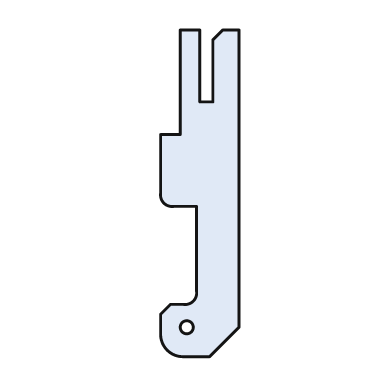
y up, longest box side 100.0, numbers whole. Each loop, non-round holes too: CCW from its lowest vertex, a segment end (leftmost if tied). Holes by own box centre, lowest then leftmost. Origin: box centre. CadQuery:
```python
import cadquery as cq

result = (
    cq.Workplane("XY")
    .moveTo(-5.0, -50.0)
    .lineTo(3.0, -50.0)
    .lineTo(12.0, -41.0)
    .lineTo(12.0, 50.0)
    .lineTo(7.0, 50.0)
    .lineTo(4.0, 47.0)
    .lineTo(4.0, 28.0)
    .lineTo(0.0, 28.0)
    .lineTo(0.0, 50.0)
    .lineTo(-6.0, 50.0)
    .lineTo(-6.0, 18.0)
    .lineTo(-12.0, 18.0)
    .lineTo(-12.0, 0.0)
    .threePointArc((-11.0, -3.0), (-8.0, -4.0))
    .lineTo(-1.0, -4.0)
    .lineTo(-1.0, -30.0)
    .threePointArc((-2.0, -33.0), (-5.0, -34.0))
    .lineTo(-9.0, -34.0)
    .lineTo(-12.0, -37.0)
    .lineTo(-12.0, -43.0)
    .threePointArc((-10.0, -48.0), (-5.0, -50.0))
    .close()
    .moveTo(-4.0, -41.0)
    .circle(2.0)
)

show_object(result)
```